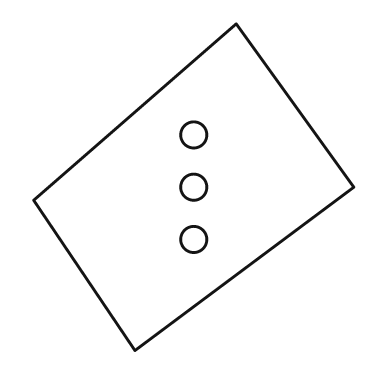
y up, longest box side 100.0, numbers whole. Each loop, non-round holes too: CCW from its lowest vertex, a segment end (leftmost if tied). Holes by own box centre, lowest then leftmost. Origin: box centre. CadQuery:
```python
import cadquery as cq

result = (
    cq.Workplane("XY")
    .moveTo(-18.0, -50.0)
    .lineTo(49.0, 0.0)
    .lineTo(13.0, 50.0)
    .lineTo(-49.0, -4.0)
    .close()
    .moveTo(0.0, -16.0)
    .circle(4.0)
    .moveTo(0.0, 0.0)
    .circle(4.0)
    .moveTo(0.0, 16.0)
    .circle(4.0)
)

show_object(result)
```